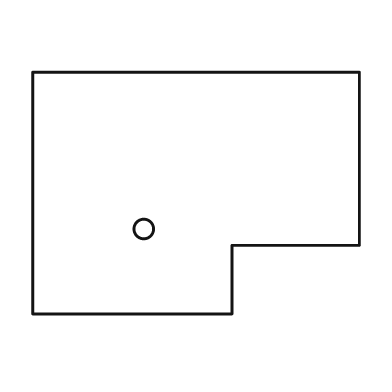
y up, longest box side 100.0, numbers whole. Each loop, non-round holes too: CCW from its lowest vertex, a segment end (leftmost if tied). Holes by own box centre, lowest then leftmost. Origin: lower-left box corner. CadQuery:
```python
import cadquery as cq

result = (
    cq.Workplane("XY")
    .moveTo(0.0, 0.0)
    .lineTo(61.0, 0.0)
    .lineTo(61.0, 21.0)
    .lineTo(100.0, 21.0)
    .lineTo(100.0, 74.0)
    .lineTo(0.0, 74.0)
    .close()
    .moveTo(34.0, 26.0)
    .circle(3.0)
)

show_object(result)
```